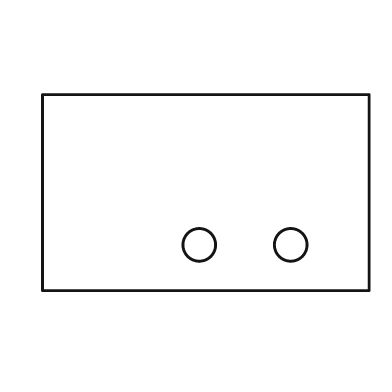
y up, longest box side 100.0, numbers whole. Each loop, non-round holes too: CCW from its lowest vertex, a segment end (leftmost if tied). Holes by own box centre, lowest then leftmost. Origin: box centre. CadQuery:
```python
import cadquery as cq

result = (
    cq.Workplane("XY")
    .moveTo(-50.0, -30.0)
    .lineTo(50.0, -30.0)
    .lineTo(50.0, 30.0)
    .lineTo(-50.0, 30.0)
    .close()
    .moveTo(-2.0, -16.0)
    .circle(5.0)
    .moveTo(26.0, -16.0)
    .circle(5.0)
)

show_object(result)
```